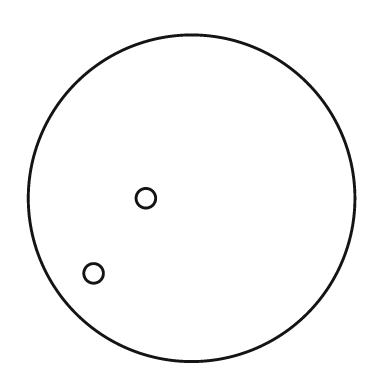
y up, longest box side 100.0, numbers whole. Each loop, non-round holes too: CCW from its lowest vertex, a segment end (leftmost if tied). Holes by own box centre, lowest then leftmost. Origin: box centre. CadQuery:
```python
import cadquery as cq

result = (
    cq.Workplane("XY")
    .moveTo(0.0, 0.0)
    .circle(50.0)
    .moveTo(-30.0, -23.0)
    .circle(3.0)
    .moveTo(-14.0, 0.0)
    .circle(3.0)
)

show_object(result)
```